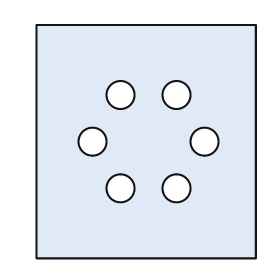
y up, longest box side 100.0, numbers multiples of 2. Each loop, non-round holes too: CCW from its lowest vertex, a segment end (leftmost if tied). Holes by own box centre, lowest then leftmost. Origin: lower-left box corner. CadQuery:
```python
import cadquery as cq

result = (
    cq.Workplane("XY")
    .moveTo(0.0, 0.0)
    .lineTo(94.0, 0.0)
    .lineTo(94.0, 100.0)
    .lineTo(0.0, 100.0)
    .close()
    .moveTo(36.0, 30.0)
    .circle(6.0)
    .moveTo(60.0, 30.0)
    .circle(6.0)
    .moveTo(24.0, 50.0)
    .circle(6.0)
    .moveTo(72.0, 50.0)
    .circle(6.0)
    .moveTo(36.0, 70.0)
    .circle(6.0)
    .moveTo(60.0, 70.0)
    .circle(6.0)
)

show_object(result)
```